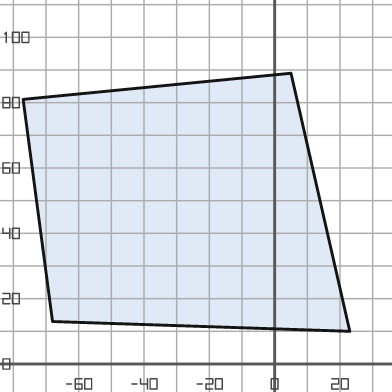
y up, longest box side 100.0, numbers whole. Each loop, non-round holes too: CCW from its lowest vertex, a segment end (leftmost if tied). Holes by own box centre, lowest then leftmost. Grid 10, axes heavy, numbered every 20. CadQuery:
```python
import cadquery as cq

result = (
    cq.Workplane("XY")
    .moveTo(23.0, 10.0)
    .lineTo(5.0, 89.0)
    .lineTo(-77.0, 81.0)
    .lineTo(-68.0, 13.0)
    .close()
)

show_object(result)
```